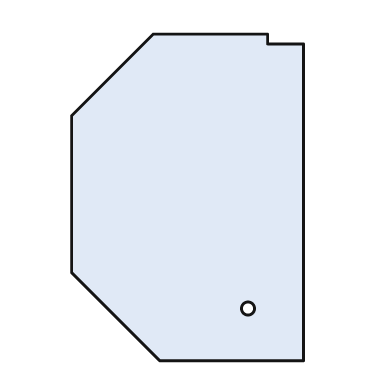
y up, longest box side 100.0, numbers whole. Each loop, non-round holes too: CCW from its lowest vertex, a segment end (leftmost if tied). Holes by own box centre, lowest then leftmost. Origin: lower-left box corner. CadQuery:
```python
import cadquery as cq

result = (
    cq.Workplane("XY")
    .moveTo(27.0, 0.0)
    .lineTo(71.0, 0.0)
    .lineTo(71.0, 97.0)
    .lineTo(60.0, 97.0)
    .lineTo(60.0, 100.0)
    .lineTo(25.0, 100.0)
    .lineTo(0.0, 75.0)
    .lineTo(0.0, 27.0)
    .close()
    .moveTo(54.0, 16.0)
    .circle(2.0)
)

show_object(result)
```